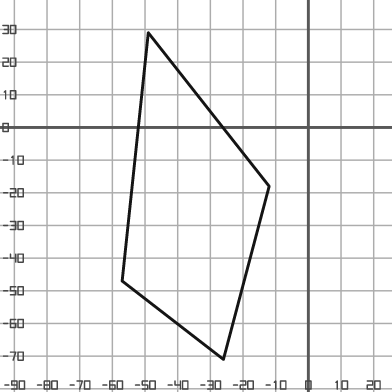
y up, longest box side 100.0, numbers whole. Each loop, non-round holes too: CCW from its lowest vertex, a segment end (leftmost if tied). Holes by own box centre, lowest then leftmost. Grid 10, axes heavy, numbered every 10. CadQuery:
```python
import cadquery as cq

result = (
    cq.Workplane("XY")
    .moveTo(-26.0, -71.0)
    .lineTo(-12.0, -18.0)
    .lineTo(-49.0, 29.0)
    .lineTo(-57.0, -47.0)
    .close()
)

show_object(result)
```